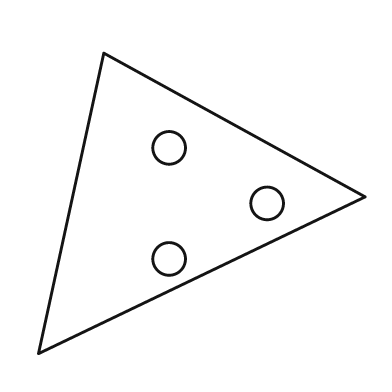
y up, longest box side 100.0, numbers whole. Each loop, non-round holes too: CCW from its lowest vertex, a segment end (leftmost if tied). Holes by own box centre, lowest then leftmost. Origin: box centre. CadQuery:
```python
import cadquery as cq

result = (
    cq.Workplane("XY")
    .moveTo(-50.0, -46.0)
    .lineTo(50.0, 2.0)
    .lineTo(-30.0, 46.0)
    .close()
    .moveTo(-10.0, -17.0)
    .circle(5.0)
    .moveTo(20.0, 0.0)
    .circle(5.0)
    .moveTo(-10.0, 17.0)
    .circle(5.0)
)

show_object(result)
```